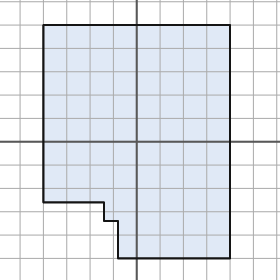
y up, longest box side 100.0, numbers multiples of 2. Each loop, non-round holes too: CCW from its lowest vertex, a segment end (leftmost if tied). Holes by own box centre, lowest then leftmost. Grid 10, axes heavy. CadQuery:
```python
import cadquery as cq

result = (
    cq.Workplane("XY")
    .moveTo(-8.0, -50.0)
    .lineTo(40.0, -50.0)
    .lineTo(40.0, 50.0)
    .lineTo(-40.0, 50.0)
    .lineTo(-40.0, -26.0)
    .lineTo(-14.0, -26.0)
    .lineTo(-14.0, -34.0)
    .lineTo(-8.0, -34.0)
    .close()
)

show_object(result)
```